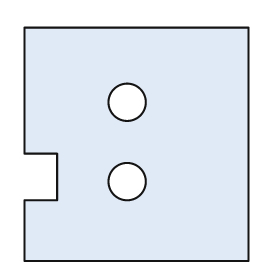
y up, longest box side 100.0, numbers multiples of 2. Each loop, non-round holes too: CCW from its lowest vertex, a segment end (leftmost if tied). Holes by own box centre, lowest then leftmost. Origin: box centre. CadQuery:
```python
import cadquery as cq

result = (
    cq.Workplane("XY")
    .moveTo(-48.0, -50.0)
    .lineTo(48.0, -50.0)
    .lineTo(48.0, 50.0)
    .lineTo(-48.0, 50.0)
    .lineTo(-48.0, -4.0)
    .lineTo(-34.0, -4.0)
    .lineTo(-34.0, -24.0)
    .lineTo(-48.0, -24.0)
    .close()
    .moveTo(-4.0, -16.0)
    .circle(8.0)
    .moveTo(-4.0, 18.0)
    .circle(8.0)
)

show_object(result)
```